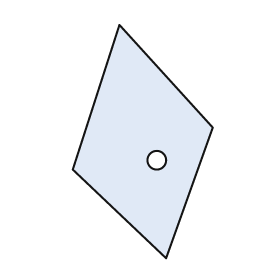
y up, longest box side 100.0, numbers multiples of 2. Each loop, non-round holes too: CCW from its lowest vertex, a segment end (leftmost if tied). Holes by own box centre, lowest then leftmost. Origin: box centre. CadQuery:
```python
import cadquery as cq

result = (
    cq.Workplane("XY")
    .moveTo(10.0, -50.0)
    .lineTo(30.0, 6.0)
    .lineTo(-10.0, 50.0)
    .lineTo(-30.0, -12.0)
    .close()
    .moveTo(6.0, -8.0)
    .circle(4.0)
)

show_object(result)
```